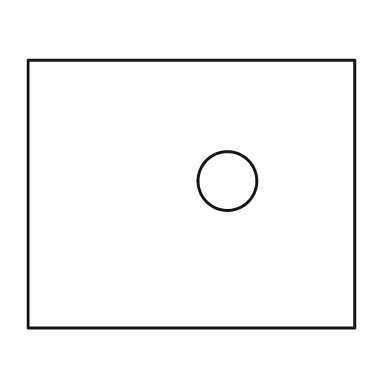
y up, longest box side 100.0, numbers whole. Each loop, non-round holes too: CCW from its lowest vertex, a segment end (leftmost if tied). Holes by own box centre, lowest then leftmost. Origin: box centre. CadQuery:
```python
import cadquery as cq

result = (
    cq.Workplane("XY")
    .moveTo(-50.0, -41.0)
    .lineTo(50.0, -41.0)
    .lineTo(50.0, 41.0)
    .lineTo(-50.0, 41.0)
    .close()
    .moveTo(11.0, 4.0)
    .circle(9.0)
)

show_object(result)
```